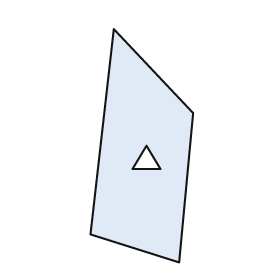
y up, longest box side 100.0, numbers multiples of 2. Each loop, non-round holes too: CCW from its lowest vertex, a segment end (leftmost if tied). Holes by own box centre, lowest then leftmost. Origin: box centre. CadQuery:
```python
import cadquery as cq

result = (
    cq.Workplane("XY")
    .moveTo(16.0, -50.0)
    .lineTo(22.0, 14.0)
    .lineTo(-12.0, 50.0)
    .lineTo(-22.0, -38.0)
    .close()
    .moveTo(-4.0, -10.0)
    .lineTo(8.0, -10.0)
    .lineTo(2.0, 0.0)
    .close()
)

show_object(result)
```